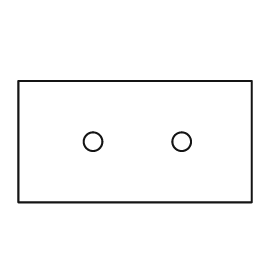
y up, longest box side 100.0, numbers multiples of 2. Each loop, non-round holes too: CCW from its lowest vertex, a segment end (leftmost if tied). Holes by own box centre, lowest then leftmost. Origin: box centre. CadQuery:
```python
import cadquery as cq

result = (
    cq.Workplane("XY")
    .moveTo(-50.0, -26.0)
    .lineTo(50.0, -26.0)
    .lineTo(50.0, 26.0)
    .lineTo(-50.0, 26.0)
    .close()
    .moveTo(-18.0, 0.0)
    .circle(4.0)
    .moveTo(20.0, 0.0)
    .circle(4.0)
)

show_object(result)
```